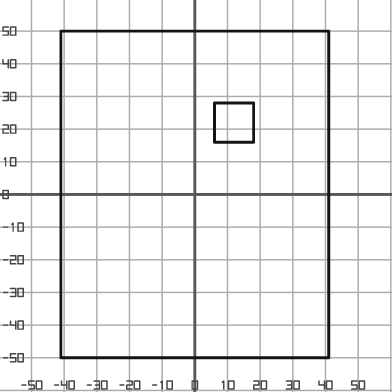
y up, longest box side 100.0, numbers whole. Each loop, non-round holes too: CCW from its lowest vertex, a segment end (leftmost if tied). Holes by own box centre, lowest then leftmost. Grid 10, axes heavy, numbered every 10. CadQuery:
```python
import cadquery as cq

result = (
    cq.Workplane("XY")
    .moveTo(-41.0, -50.0)
    .lineTo(41.0, -50.0)
    .lineTo(41.0, 50.0)
    .lineTo(-41.0, 50.0)
    .close()
    .moveTo(6.0, 16.0)
    .lineTo(18.0, 16.0)
    .lineTo(18.0, 28.0)
    .lineTo(6.0, 28.0)
    .close()
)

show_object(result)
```